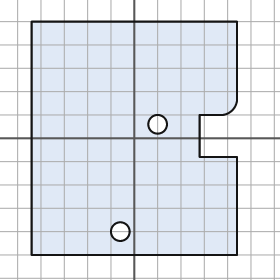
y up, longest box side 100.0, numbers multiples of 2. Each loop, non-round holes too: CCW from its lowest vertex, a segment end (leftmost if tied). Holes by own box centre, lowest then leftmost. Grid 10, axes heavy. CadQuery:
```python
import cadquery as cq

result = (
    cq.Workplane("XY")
    .moveTo(-44.0, -50.0)
    .lineTo(44.0, -50.0)
    .lineTo(44.0, -8.0)
    .lineTo(28.0, -8.0)
    .lineTo(28.0, 10.0)
    .lineTo(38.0, 10.0)
    .threePointArc((42.0, 12.0), (44.0, 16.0))
    .lineTo(44.0, 50.0)
    .lineTo(-44.0, 50.0)
    .close()
    .moveTo(-6.0, -40.0)
    .circle(4.0)
    .moveTo(10.0, 6.0)
    .circle(4.0)
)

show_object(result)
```